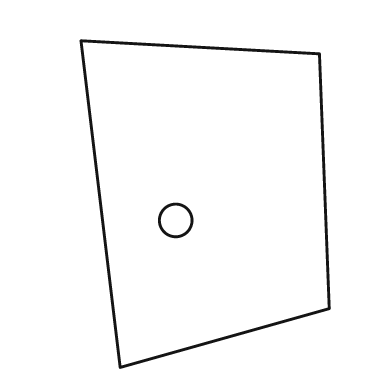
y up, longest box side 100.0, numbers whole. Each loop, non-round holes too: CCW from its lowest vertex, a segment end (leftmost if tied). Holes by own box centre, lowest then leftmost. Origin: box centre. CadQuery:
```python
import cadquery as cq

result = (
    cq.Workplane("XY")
    .moveTo(-26.0, -50.0)
    .lineTo(38.0, -32.0)
    .lineTo(35.0, 46.0)
    .lineTo(-38.0, 50.0)
    .close()
    .moveTo(-9.0, -5.0)
    .circle(5.0)
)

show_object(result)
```